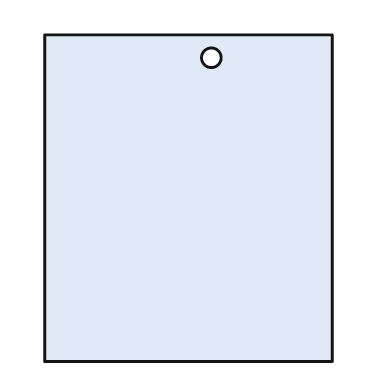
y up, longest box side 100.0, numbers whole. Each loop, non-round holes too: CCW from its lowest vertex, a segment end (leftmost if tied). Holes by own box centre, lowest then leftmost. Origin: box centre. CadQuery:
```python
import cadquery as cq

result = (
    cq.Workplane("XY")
    .moveTo(-44.0, -50.0)
    .lineTo(44.0, -50.0)
    .lineTo(44.0, 50.0)
    .lineTo(-44.0, 50.0)
    .close()
    .moveTo(7.0, 43.0)
    .circle(3.0)
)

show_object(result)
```